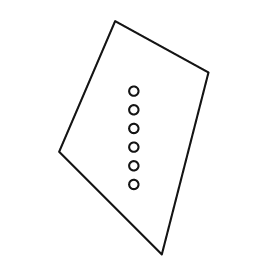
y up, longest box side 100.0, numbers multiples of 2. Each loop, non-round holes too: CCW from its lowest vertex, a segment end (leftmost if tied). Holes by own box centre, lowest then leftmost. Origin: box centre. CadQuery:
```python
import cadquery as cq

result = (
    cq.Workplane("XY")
    .moveTo(12.0, -50.0)
    .lineTo(32.0, 28.0)
    .lineTo(-8.0, 50.0)
    .lineTo(-32.0, -6.0)
    .close()
    .moveTo(0.0, -20.0)
    .circle(2.0)
    .moveTo(0.0, -12.0)
    .circle(2.0)
    .moveTo(0.0, -4.0)
    .circle(2.0)
    .moveTo(0.0, 4.0)
    .circle(2.0)
    .moveTo(0.0, 12.0)
    .circle(2.0)
    .moveTo(0.0, 20.0)
    .circle(2.0)
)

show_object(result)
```